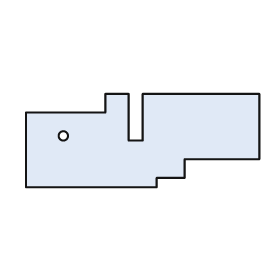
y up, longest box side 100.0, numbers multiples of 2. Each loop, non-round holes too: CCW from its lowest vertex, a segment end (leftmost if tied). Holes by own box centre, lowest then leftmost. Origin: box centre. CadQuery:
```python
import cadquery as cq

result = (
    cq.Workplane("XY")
    .moveTo(-50.0, -20.0)
    .lineTo(6.0, -20.0)
    .lineTo(6.0, -16.0)
    .lineTo(18.0, -16.0)
    .lineTo(18.0, -8.0)
    .lineTo(50.0, -8.0)
    .lineTo(50.0, 20.0)
    .lineTo(0.0, 20.0)
    .lineTo(0.0, 0.0)
    .lineTo(-6.0, 0.0)
    .lineTo(-6.0, 20.0)
    .lineTo(-16.0, 20.0)
    .lineTo(-16.0, 12.0)
    .lineTo(-50.0, 12.0)
    .close()
    .moveTo(-34.0, 2.0)
    .circle(2.0)
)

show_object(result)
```